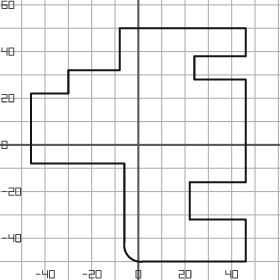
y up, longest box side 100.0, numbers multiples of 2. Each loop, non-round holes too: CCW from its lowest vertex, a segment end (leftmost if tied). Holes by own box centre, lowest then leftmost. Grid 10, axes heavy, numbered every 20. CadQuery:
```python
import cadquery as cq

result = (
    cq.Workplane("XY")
    .moveTo(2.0, -50.0)
    .lineTo(46.0, -50.0)
    .lineTo(46.0, -32.0)
    .lineTo(22.0, -32.0)
    .lineTo(22.0, -16.0)
    .lineTo(46.0, -16.0)
    .lineTo(46.0, 28.0)
    .lineTo(24.0, 28.0)
    .lineTo(24.0, 38.0)
    .lineTo(46.0, 38.0)
    .lineTo(46.0, 50.0)
    .lineTo(-8.0, 50.0)
    .lineTo(-8.0, 32.0)
    .lineTo(-30.0, 32.0)
    .lineTo(-30.0, 22.0)
    .lineTo(-46.0, 22.0)
    .lineTo(-46.0, -8.0)
    .lineTo(-6.0, -8.0)
    .lineTo(-6.0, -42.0)
    .threePointArc((-4.0, -48.0), (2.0, -50.0))
    .close()
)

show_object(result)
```